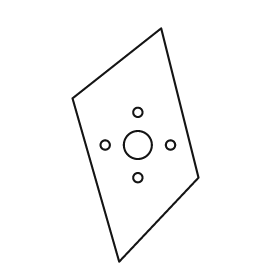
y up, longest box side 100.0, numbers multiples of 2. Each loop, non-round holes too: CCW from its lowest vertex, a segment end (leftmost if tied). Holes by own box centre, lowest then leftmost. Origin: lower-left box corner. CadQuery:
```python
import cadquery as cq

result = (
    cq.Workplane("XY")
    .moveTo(20.0, 0.0)
    .lineTo(54.0, 36.0)
    .lineTo(38.0, 100.0)
    .lineTo(0.0, 70.0)
    .close()
    .moveTo(28.0, 36.0)
    .circle(2.0)
    .moveTo(14.0, 50.0)
    .circle(2.0)
    .moveTo(28.0, 50.0)
    .circle(6.0)
    .moveTo(42.0, 50.0)
    .circle(2.0)
    .moveTo(28.0, 64.0)
    .circle(2.0)
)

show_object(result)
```